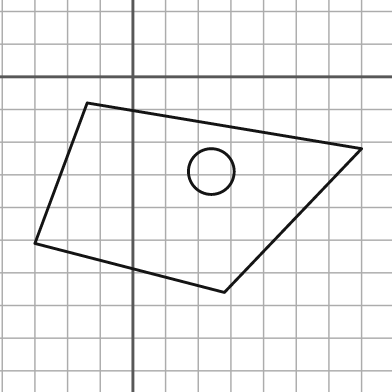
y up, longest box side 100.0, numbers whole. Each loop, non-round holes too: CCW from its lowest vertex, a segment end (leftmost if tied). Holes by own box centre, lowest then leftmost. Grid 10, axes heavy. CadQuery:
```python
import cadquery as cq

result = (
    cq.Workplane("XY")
    .moveTo(28.0, -66.0)
    .lineTo(70.0, -22.0)
    .lineTo(-14.0, -8.0)
    .lineTo(-30.0, -51.0)
    .close()
    .moveTo(24.0, -29.0)
    .circle(7.0)
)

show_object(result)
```